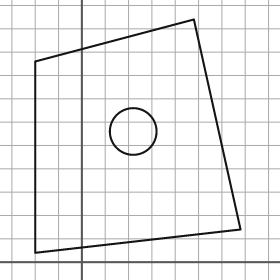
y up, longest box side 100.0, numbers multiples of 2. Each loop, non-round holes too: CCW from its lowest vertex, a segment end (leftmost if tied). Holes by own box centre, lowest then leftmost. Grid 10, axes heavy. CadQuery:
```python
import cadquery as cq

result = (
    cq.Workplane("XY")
    .moveTo(-20.0, 4.0)
    .lineTo(68.0, 14.0)
    .lineTo(48.0, 104.0)
    .lineTo(-20.0, 86.0)
    .close()
    .moveTo(22.0, 56.0)
    .circle(10.0)
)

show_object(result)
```